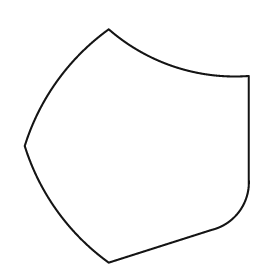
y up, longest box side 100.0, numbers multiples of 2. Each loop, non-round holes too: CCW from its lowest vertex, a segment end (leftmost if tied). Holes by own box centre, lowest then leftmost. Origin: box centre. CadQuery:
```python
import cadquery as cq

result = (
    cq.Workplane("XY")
    .moveTo(-12.0, -50.0)
    .lineTo(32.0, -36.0)
    .threePointArc((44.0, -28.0), (48.0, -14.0))
    .lineTo(48.0, 30.0)
    .threePointArc((16.0, 34.0), (-12.0, 50.0))
    .threePointArc((-34.0, 28.0), (-48.0, 0.0))
    .threePointArc((-34.0, -28.0), (-12.0, -50.0))
    .close()
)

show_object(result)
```